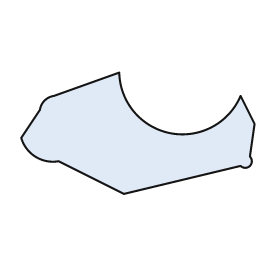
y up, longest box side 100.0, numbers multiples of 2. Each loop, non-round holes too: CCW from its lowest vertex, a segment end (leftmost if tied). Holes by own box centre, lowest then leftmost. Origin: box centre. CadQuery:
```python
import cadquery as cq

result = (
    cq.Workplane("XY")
    .moveTo(-6.0, -26.0)
    .lineTo(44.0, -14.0)
    .threePointArc((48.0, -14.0), (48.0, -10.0))
    .lineTo(50.0, 4.0)
    .lineTo(44.0, 16.0)
    .threePointArc((14.0, 0.0), (-8.0, 26.0))
    .lineTo(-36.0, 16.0)
    .threePointArc((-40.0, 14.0), (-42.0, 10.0))
    .lineTo(-50.0, -2.0)
    .threePointArc((-44.0, -10.0), (-34.0, -12.0))
    .close()
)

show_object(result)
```